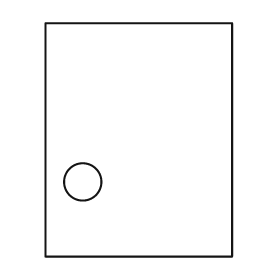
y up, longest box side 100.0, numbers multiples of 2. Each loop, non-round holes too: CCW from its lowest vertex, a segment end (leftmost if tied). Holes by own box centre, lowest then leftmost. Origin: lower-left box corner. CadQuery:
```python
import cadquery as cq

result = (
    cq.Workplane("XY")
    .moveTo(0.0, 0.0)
    .lineTo(80.0, 0.0)
    .lineTo(80.0, 100.0)
    .lineTo(0.0, 100.0)
    .close()
    .moveTo(16.0, 32.0)
    .circle(8.0)
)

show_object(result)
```